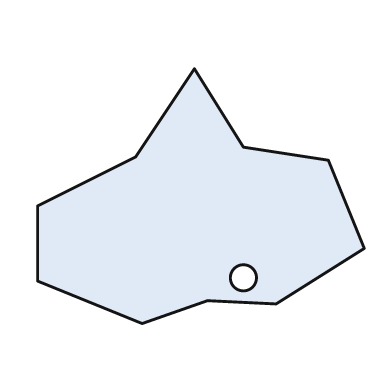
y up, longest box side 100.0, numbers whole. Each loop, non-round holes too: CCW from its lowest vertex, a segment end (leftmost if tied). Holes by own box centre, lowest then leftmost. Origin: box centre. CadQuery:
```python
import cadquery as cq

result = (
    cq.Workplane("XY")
    .moveTo(-18.0, -39.0)
    .lineTo(2.0, -32.0)
    .lineTo(23.0, -33.0)
    .lineTo(50.0, -16.0)
    .lineTo(39.0, 11.0)
    .lineTo(13.0, 15.0)
    .lineTo(-2.0, 39.0)
    .lineTo(-20.0, 12.0)
    .lineTo(-50.0, -3.0)
    .lineTo(-50.0, -26.0)
    .close()
    .moveTo(13.0, -25.0)
    .circle(4.0)
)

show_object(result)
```